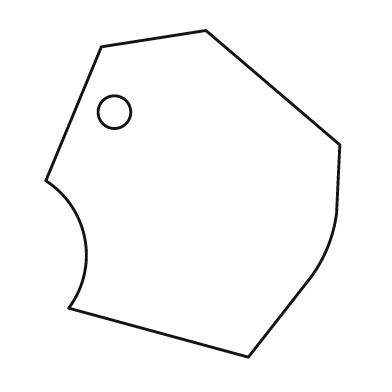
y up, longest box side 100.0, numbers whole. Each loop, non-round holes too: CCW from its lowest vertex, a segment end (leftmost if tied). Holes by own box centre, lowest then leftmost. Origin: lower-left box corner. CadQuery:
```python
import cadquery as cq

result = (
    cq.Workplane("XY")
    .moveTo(62.0, 0.0)
    .lineTo(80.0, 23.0)
    .threePointArc((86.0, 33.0), (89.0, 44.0))
    .lineTo(90.0, 65.0)
    .lineTo(49.0, 100.0)
    .lineTo(17.0, 95.0)
    .lineTo(0.0, 54.0)
    .threePointArc((12.0, 36.0), (7.0, 15.0))
    .close()
    .moveTo(21.0, 75.0)
    .circle(5.0)
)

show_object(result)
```